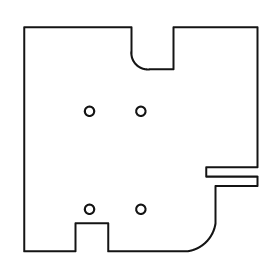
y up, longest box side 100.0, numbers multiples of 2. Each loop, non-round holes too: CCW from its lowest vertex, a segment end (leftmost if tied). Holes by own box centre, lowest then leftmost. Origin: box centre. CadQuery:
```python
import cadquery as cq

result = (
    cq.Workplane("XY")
    .moveTo(-50.0, -48.0)
    .lineTo(-28.0, -48.0)
    .lineTo(-28.0, -36.0)
    .lineTo(-14.0, -36.0)
    .lineTo(-14.0, -48.0)
    .lineTo(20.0, -48.0)
    .threePointArc((28.0, -44.0), (32.0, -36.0))
    .lineTo(32.0, -20.0)
    .lineTo(50.0, -20.0)
    .lineTo(50.0, -16.0)
    .lineTo(28.0, -16.0)
    .lineTo(28.0, -12.0)
    .lineTo(50.0, -12.0)
    .lineTo(50.0, 48.0)
    .lineTo(14.0, 48.0)
    .lineTo(14.0, 30.0)
    .lineTo(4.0, 30.0)
    .threePointArc((-2.0, 32.0), (-4.0, 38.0))
    .lineTo(-4.0, 48.0)
    .lineTo(-50.0, 48.0)
    .close()
    .moveTo(-22.0, -30.0)
    .circle(2.0)
    .moveTo(0.0, -30.0)
    .circle(2.0)
    .moveTo(-22.0, 12.0)
    .circle(2.0)
    .moveTo(0.0, 12.0)
    .circle(2.0)
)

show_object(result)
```